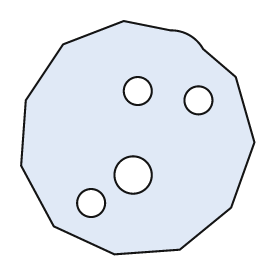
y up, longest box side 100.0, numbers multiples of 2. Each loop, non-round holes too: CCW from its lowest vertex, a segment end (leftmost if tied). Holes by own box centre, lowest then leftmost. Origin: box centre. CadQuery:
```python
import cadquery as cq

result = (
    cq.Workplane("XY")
    .moveTo(-10.0, -50.0)
    .lineTo(18.0, -48.0)
    .lineTo(40.0, -30.0)
    .lineTo(50.0, -2.0)
    .lineTo(42.0, 26.0)
    .lineTo(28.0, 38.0)
    .threePointArc((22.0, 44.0), (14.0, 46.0))
    .lineTo(-6.0, 50.0)
    .lineTo(-32.0, 40.0)
    .lineTo(-48.0, 16.0)
    .lineTo(-50.0, -12.0)
    .lineTo(-36.0, -38.0)
    .close()
    .moveTo(-20.0, -28.0)
    .circle(6.0)
    .moveTo(-2.0, -16.0)
    .circle(8.0)
    .moveTo(26.0, 16.0)
    .circle(6.0)
    .moveTo(0.0, 20.0)
    .circle(6.0)
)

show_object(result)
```